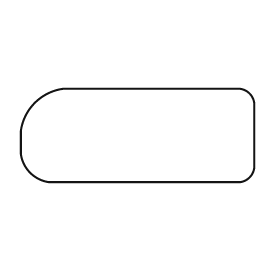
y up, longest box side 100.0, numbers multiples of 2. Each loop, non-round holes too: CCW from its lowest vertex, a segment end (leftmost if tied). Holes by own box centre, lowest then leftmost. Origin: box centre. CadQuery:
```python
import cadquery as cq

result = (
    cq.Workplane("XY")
    .moveTo(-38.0, -20.0)
    .lineTo(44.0, -20.0)
    .threePointArc((48.0, -18.0), (50.0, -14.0))
    .lineTo(50.0, 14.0)
    .threePointArc((48.0, 18.0), (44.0, 20.0))
    .lineTo(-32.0, 20.0)
    .threePointArc((-44.0, 14.0), (-50.0, 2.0))
    .lineTo(-50.0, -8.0)
    .threePointArc((-46.0, -16.0), (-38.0, -20.0))
    .close()
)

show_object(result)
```